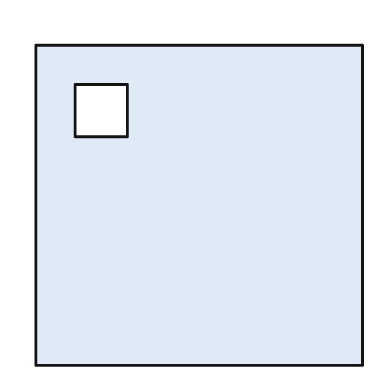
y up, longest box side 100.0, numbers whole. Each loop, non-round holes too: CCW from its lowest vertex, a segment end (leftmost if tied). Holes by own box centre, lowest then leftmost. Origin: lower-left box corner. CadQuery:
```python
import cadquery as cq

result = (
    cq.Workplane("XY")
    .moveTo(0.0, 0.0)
    .lineTo(100.0, 0.0)
    .lineTo(100.0, 98.0)
    .lineTo(0.0, 98.0)
    .close()
    .moveTo(12.0, 70.0)
    .lineTo(28.0, 70.0)
    .lineTo(28.0, 86.0)
    .lineTo(12.0, 86.0)
    .close()
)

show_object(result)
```